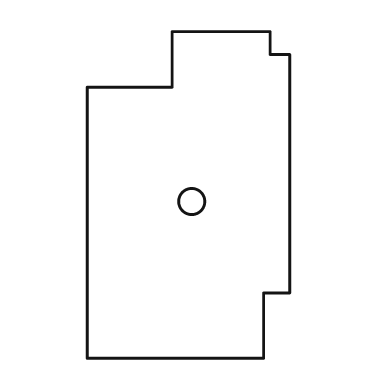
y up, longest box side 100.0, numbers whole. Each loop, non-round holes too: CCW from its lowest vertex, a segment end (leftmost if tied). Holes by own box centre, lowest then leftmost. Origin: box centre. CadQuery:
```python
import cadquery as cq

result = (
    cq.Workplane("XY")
    .moveTo(-31.0, -50.0)
    .lineTo(23.0, -50.0)
    .lineTo(23.0, -30.0)
    .lineTo(31.0, -30.0)
    .lineTo(31.0, 43.0)
    .lineTo(25.0, 43.0)
    .lineTo(25.0, 50.0)
    .lineTo(-5.0, 50.0)
    .lineTo(-5.0, 33.0)
    .lineTo(-31.0, 33.0)
    .close()
    .moveTo(1.0, -2.0)
    .circle(4.0)
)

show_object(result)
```